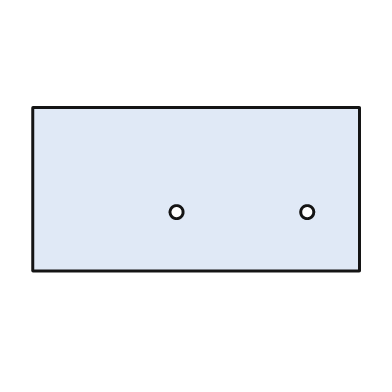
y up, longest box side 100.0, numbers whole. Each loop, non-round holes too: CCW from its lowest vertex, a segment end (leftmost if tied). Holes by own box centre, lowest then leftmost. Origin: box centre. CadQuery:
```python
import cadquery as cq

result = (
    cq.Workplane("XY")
    .moveTo(-50.0, -25.0)
    .lineTo(50.0, -25.0)
    .lineTo(50.0, 25.0)
    .lineTo(-50.0, 25.0)
    .close()
    .moveTo(-6.0, -7.0)
    .circle(2.0)
    .moveTo(34.0, -7.0)
    .circle(2.0)
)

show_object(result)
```